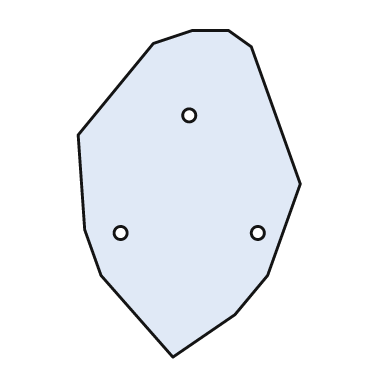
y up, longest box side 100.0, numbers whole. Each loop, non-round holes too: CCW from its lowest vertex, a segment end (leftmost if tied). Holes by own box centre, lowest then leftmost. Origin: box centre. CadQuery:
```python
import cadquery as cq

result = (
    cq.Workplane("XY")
    .moveTo(-5.0, -50.0)
    .lineTo(14.0, -37.0)
    .lineTo(24.0, -25.0)
    .lineTo(34.0, 3.0)
    .lineTo(19.0, 45.0)
    .lineTo(12.0, 50.0)
    .lineTo(1.0, 50.0)
    .lineTo(-11.0, 46.0)
    .lineTo(-34.0, 18.0)
    .lineTo(-32.0, -11.0)
    .lineTo(-27.0, -25.0)
    .close()
    .moveTo(-21.0, -12.0)
    .circle(2.0)
    .moveTo(21.0, -12.0)
    .circle(2.0)
    .moveTo(0.0, 24.0)
    .circle(2.0)
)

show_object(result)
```